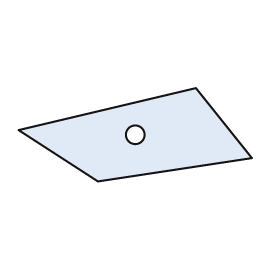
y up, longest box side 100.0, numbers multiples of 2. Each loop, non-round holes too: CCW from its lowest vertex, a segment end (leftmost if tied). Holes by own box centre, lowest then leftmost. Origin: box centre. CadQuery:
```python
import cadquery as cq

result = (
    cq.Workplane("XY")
    .moveTo(-16.0, -20.0)
    .lineTo(50.0, -10.0)
    .lineTo(26.0, 20.0)
    .lineTo(-50.0, 2.0)
    .close()
    .moveTo(0.0, 0.0)
    .circle(4.0)
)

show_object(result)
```